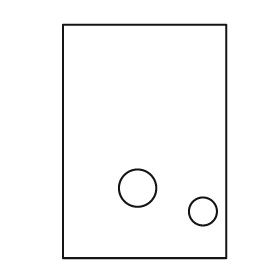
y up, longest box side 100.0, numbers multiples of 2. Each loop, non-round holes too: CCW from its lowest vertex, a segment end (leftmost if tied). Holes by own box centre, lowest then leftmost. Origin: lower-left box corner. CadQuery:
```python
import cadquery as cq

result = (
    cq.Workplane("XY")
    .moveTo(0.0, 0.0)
    .lineTo(70.0, 0.0)
    .lineTo(70.0, 100.0)
    .lineTo(0.0, 100.0)
    .close()
    .moveTo(60.0, 20.0)
    .circle(6.0)
    .moveTo(32.0, 30.0)
    .circle(8.0)
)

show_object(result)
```